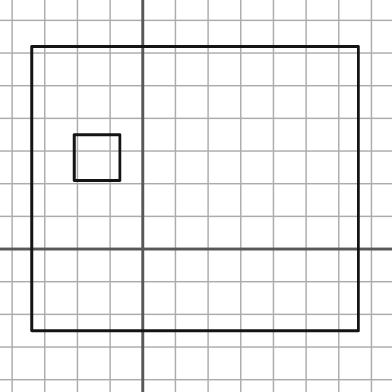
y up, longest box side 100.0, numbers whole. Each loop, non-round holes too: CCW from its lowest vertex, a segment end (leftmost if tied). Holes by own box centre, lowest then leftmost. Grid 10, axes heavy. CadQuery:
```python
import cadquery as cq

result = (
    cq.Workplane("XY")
    .moveTo(-34.0, -25.0)
    .lineTo(66.0, -25.0)
    .lineTo(66.0, 62.0)
    .lineTo(-34.0, 62.0)
    .close()
    .moveTo(-21.0, 21.0)
    .lineTo(-7.0, 21.0)
    .lineTo(-7.0, 35.0)
    .lineTo(-21.0, 35.0)
    .close()
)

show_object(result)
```